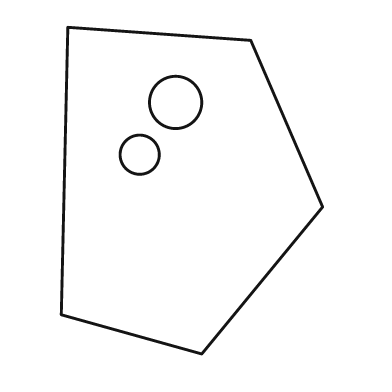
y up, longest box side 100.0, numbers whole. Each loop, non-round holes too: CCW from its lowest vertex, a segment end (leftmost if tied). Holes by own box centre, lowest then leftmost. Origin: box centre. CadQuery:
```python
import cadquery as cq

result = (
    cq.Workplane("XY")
    .moveTo(3.0, -50.0)
    .lineTo(40.0, -5.0)
    .lineTo(18.0, 46.0)
    .lineTo(-38.0, 50.0)
    .lineTo(-40.0, -38.0)
    .close()
    .moveTo(-16.0, 11.0)
    .circle(6.0)
    .moveTo(-5.0, 27.0)
    .circle(8.0)
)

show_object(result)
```